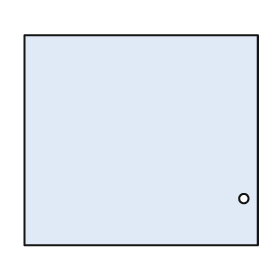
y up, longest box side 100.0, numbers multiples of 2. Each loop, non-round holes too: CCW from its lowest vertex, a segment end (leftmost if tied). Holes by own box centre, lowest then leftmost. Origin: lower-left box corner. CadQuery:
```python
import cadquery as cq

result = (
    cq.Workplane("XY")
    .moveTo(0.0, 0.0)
    .lineTo(100.0, 0.0)
    .lineTo(100.0, 90.0)
    .lineTo(0.0, 90.0)
    .close()
    .moveTo(94.0, 20.0)
    .circle(2.0)
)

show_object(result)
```